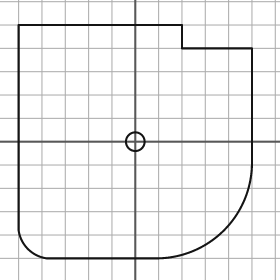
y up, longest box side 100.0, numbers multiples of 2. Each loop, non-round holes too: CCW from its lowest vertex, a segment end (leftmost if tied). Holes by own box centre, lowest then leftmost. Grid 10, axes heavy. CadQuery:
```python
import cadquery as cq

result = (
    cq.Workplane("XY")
    .moveTo(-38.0, -50.0)
    .lineTo(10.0, -50.0)
    .threePointArc((38.0, -38.0), (50.0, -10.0))
    .lineTo(50.0, 40.0)
    .lineTo(20.0, 40.0)
    .lineTo(20.0, 50.0)
    .lineTo(-50.0, 50.0)
    .lineTo(-50.0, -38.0)
    .threePointArc((-46.0, -46.0), (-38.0, -50.0))
    .close()
    .moveTo(0.0, 0.0)
    .circle(4.0)
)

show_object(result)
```